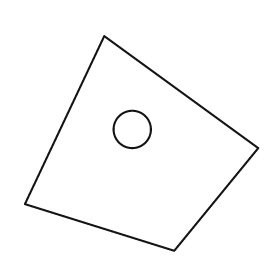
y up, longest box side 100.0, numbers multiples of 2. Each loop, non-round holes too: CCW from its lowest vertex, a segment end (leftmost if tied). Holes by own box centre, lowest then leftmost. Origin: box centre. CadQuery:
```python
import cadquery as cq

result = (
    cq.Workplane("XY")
    .moveTo(14.0, -46.0)
    .lineTo(50.0, -2.0)
    .lineTo(-16.0, 46.0)
    .lineTo(-50.0, -26.0)
    .close()
    .moveTo(-4.0, 6.0)
    .circle(8.0)
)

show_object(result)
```